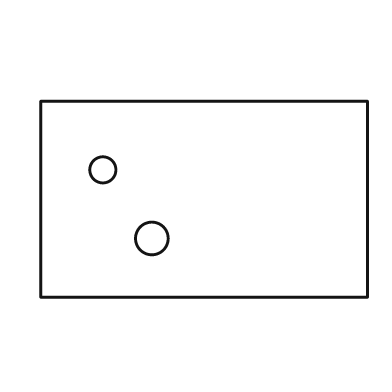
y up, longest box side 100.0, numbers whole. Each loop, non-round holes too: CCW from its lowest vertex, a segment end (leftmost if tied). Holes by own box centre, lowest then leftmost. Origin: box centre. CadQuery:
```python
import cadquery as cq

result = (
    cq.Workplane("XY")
    .moveTo(-50.0, -30.0)
    .lineTo(50.0, -30.0)
    .lineTo(50.0, 30.0)
    .lineTo(-50.0, 30.0)
    .close()
    .moveTo(-16.0, -12.0)
    .circle(5.0)
    .moveTo(-31.0, 9.0)
    .circle(4.0)
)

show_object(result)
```